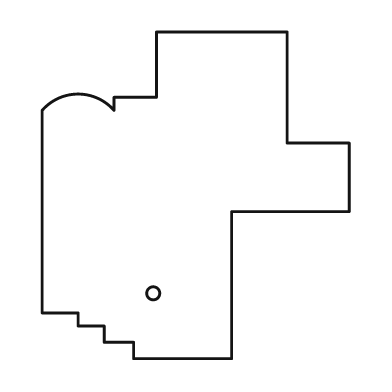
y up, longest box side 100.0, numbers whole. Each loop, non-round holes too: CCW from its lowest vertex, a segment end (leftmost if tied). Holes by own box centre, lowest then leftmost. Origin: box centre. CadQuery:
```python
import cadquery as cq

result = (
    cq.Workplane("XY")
    .moveTo(-19.0, -50.0)
    .lineTo(11.0, -50.0)
    .lineTo(11.0, -5.0)
    .lineTo(47.0, -5.0)
    .lineTo(47.0, 16.0)
    .lineTo(28.0, 16.0)
    .lineTo(28.0, 50.0)
    .lineTo(-12.0, 50.0)
    .lineTo(-12.0, 30.0)
    .lineTo(-25.0, 30.0)
    .lineTo(-25.0, 26.0)
    .threePointArc((-36.0, 31.0), (-47.0, 26.0))
    .lineTo(-47.0, -36.0)
    .lineTo(-36.0, -36.0)
    .lineTo(-36.0, -40.0)
    .lineTo(-28.0, -40.0)
    .lineTo(-28.0, -45.0)
    .lineTo(-19.0, -45.0)
    .close()
    .moveTo(-13.0, -30.0)
    .circle(2.0)
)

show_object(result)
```